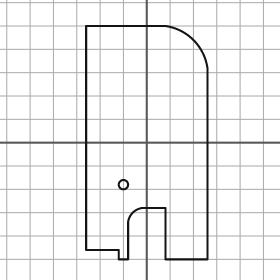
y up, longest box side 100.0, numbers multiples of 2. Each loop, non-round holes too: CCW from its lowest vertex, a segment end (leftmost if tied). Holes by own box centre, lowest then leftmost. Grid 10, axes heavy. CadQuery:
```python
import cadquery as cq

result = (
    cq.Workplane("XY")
    .moveTo(-12.0, -50.0)
    .lineTo(-8.0, -50.0)
    .lineTo(-8.0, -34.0)
    .threePointArc((-6.0, -30.0), (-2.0, -28.0))
    .lineTo(8.0, -28.0)
    .lineTo(8.0, -50.0)
    .lineTo(26.0, -50.0)
    .lineTo(26.0, 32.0)
    .threePointArc((20.0, 44.0), (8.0, 50.0))
    .lineTo(-26.0, 50.0)
    .lineTo(-26.0, -46.0)
    .lineTo(-12.0, -46.0)
    .close()
    .moveTo(-10.0, -18.0)
    .circle(2.0)
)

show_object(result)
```